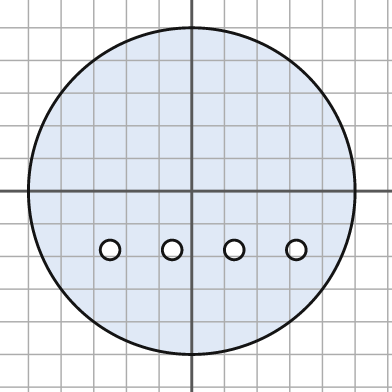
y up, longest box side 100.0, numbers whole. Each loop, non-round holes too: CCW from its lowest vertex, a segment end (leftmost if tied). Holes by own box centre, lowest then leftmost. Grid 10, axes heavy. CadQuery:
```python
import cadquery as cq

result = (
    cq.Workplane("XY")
    .moveTo(0.0, 0.0)
    .circle(50.0)
    .moveTo(-25.0, -18.0)
    .circle(3.0)
    .moveTo(-6.0, -18.0)
    .circle(3.0)
    .moveTo(13.0, -18.0)
    .circle(3.0)
    .moveTo(32.0, -18.0)
    .circle(3.0)
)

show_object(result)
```